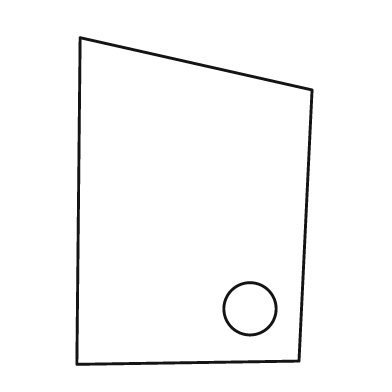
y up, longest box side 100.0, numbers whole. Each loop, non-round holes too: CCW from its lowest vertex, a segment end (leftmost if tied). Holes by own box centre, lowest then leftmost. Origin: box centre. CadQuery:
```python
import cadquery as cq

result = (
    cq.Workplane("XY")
    .moveTo(-36.0, -50.0)
    .lineTo(32.0, -49.0)
    .lineTo(36.0, 34.0)
    .lineTo(-35.0, 50.0)
    .close()
    .moveTo(17.0, -33.0)
    .circle(8.0)
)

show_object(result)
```